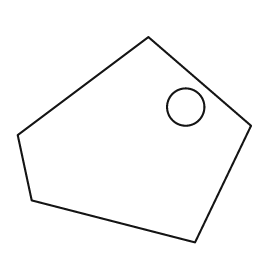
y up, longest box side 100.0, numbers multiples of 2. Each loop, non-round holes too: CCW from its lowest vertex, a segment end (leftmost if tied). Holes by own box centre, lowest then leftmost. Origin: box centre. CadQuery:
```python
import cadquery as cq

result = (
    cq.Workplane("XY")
    .moveTo(26.0, -44.0)
    .lineTo(50.0, 6.0)
    .lineTo(6.0, 44.0)
    .lineTo(-50.0, 2.0)
    .lineTo(-44.0, -26.0)
    .close()
    .moveTo(22.0, 14.0)
    .circle(8.0)
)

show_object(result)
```